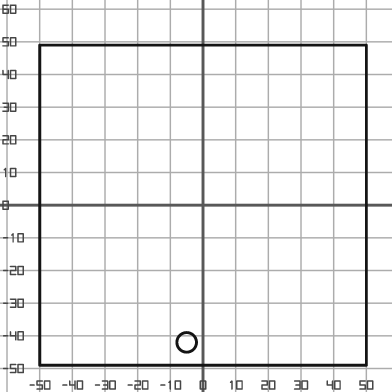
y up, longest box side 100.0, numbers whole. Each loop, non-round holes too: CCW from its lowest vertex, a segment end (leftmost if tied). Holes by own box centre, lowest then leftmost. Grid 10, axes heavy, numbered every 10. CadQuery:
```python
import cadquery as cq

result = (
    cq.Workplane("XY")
    .moveTo(-50.0, -49.0)
    .lineTo(50.0, -49.0)
    .lineTo(50.0, 49.0)
    .lineTo(-50.0, 49.0)
    .close()
    .moveTo(-5.0, -42.0)
    .circle(3.0)
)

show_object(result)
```